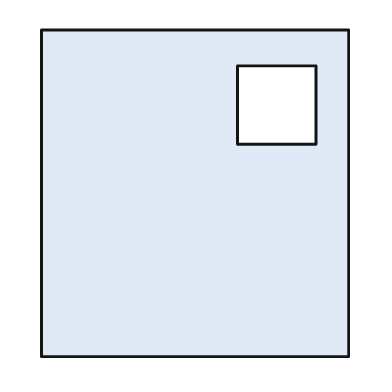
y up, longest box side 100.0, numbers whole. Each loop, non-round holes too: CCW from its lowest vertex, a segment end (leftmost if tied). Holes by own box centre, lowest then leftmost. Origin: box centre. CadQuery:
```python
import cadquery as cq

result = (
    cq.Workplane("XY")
    .moveTo(-47.0, -50.0)
    .lineTo(47.0, -50.0)
    .lineTo(47.0, 50.0)
    .lineTo(-47.0, 50.0)
    .close()
    .moveTo(13.0, 15.0)
    .lineTo(37.0, 15.0)
    .lineTo(37.0, 39.0)
    .lineTo(13.0, 39.0)
    .close()
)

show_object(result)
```